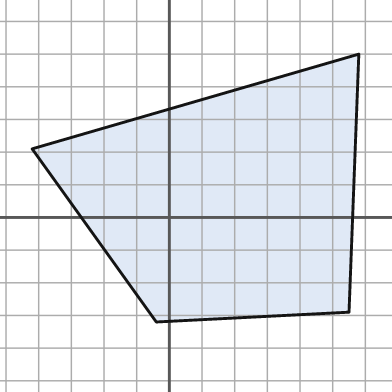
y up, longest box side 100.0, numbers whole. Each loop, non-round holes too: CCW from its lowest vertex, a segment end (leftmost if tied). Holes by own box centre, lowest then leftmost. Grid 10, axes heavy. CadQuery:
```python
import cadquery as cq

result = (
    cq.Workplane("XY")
    .moveTo(-4.0, -32.0)
    .lineTo(55.0, -29.0)
    .lineTo(58.0, 50.0)
    .lineTo(-42.0, 21.0)
    .close()
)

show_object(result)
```